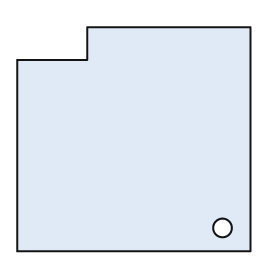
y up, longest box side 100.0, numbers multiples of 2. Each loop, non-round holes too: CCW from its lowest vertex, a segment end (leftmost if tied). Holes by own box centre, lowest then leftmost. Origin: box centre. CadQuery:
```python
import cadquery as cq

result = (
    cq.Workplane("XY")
    .moveTo(-50.0, -48.0)
    .lineTo(50.0, -48.0)
    .lineTo(50.0, 48.0)
    .lineTo(-20.0, 48.0)
    .lineTo(-20.0, 34.0)
    .lineTo(-50.0, 34.0)
    .close()
    .moveTo(38.0, -38.0)
    .circle(4.0)
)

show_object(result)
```